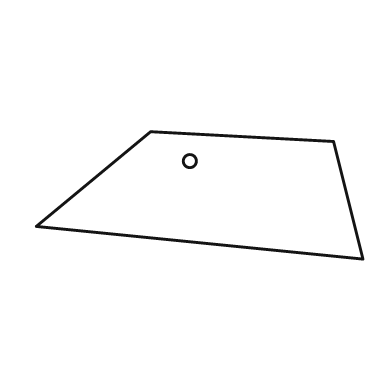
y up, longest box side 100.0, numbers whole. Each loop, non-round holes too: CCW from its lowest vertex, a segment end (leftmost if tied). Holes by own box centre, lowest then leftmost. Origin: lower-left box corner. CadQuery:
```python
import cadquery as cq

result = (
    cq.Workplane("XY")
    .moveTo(100.0, 0.0)
    .lineTo(91.0, 36.0)
    .lineTo(35.0, 39.0)
    .lineTo(0.0, 10.0)
    .close()
    .moveTo(47.0, 30.0)
    .circle(2.0)
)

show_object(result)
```